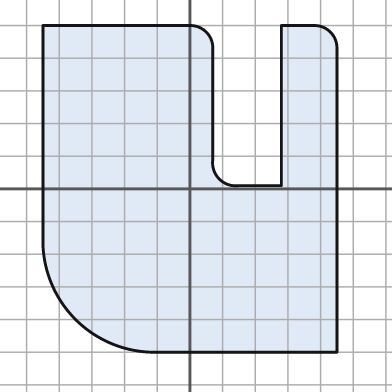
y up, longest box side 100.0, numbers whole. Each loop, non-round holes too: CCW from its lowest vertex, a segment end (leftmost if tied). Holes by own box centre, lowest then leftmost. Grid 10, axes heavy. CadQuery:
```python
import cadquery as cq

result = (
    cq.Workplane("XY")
    .moveTo(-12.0, -50.0)
    .lineTo(45.0, -50.0)
    .lineTo(45.0, 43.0)
    .threePointArc((43.0, 48.0), (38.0, 50.0))
    .lineTo(28.0, 50.0)
    .lineTo(28.0, 1.0)
    .lineTo(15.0, 1.0)
    .threePointArc((9.0, 3.0), (7.0, 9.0))
    .lineTo(7.0, 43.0)
    .threePointArc((5.0, 48.0), (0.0, 50.0))
    .lineTo(-45.0, 50.0)
    .lineTo(-45.0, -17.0)
    .threePointArc((-35.0, -40.0), (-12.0, -50.0))
    .close()
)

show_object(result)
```